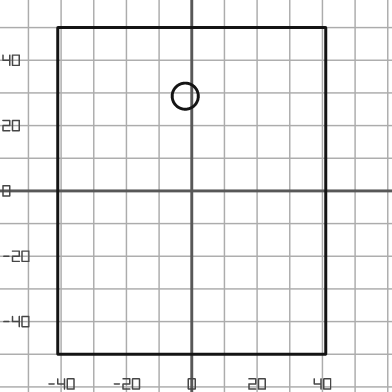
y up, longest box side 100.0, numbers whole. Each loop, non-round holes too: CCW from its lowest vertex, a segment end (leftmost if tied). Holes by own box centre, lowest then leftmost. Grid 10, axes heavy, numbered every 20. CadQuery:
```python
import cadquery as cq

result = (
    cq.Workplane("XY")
    .moveTo(-41.0, -50.0)
    .lineTo(41.0, -50.0)
    .lineTo(41.0, 50.0)
    .lineTo(-41.0, 50.0)
    .close()
    .moveTo(-2.0, 29.0)
    .circle(4.0)
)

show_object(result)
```